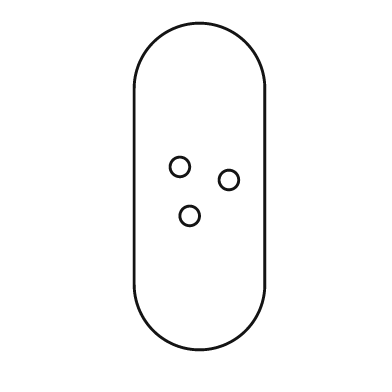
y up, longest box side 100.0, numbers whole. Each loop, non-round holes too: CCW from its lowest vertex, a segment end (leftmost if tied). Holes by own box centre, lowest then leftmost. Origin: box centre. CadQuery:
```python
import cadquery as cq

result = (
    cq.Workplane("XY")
    .moveTo(-20.0, -30.0)
    .threePointArc((0.0, -50.0), (20.0, -30.0))
    .lineTo(20.0, 30.0)
    .threePointArc((0.0, 50.0), (-20.0, 30.0))
    .close()
    .moveTo(-3.0, -9.0)
    .circle(3.0)
    .moveTo(9.0, 2.0)
    .circle(3.0)
    .moveTo(-6.0, 6.0)
    .circle(3.0)
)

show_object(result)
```